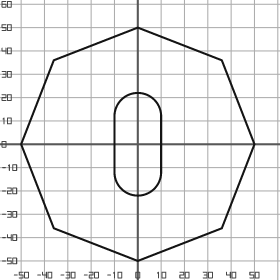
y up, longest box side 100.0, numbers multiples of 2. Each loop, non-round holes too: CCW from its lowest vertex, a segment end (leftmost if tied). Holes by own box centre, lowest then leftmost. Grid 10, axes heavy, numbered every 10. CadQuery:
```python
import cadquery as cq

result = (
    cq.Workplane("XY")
    .moveTo(0.0, -50.0)
    .lineTo(36.0, -36.0)
    .lineTo(50.0, 0.0)
    .lineTo(36.0, 36.0)
    .lineTo(0.0, 50.0)
    .lineTo(-36.0, 36.0)
    .lineTo(-50.0, 0.0)
    .lineTo(-36.0, -36.0)
    .close()
    .moveTo(-10.0, -12.0)
    .threePointArc((0.0, -22.0), (10.0, -12.0))
    .lineTo(10.0, 12.0)
    .threePointArc((0.0, 22.0), (-10.0, 12.0))
    .close()
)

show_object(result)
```